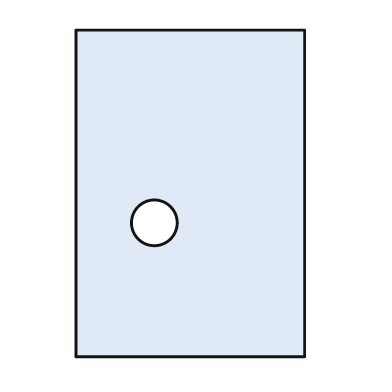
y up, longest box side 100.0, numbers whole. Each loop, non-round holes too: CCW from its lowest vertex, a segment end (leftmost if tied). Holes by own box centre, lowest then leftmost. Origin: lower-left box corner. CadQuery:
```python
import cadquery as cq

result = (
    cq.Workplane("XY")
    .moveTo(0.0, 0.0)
    .lineTo(70.0, 0.0)
    .lineTo(70.0, 100.0)
    .lineTo(0.0, 100.0)
    .close()
    .moveTo(24.0, 41.0)
    .circle(7.0)
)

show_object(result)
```